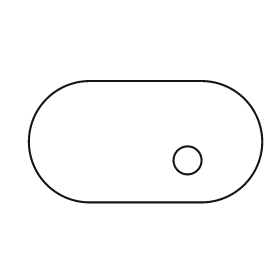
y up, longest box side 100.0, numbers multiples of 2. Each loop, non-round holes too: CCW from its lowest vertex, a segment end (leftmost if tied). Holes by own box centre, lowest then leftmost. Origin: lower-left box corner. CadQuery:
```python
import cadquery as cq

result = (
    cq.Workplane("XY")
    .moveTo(26.0, 0.0)
    .lineTo(74.0, 0.0)
    .threePointArc((100.0, 26.0), (74.0, 52.0))
    .lineTo(26.0, 52.0)
    .threePointArc((0.0, 26.0), (26.0, 0.0))
    .close()
    .moveTo(68.0, 18.0)
    .circle(6.0)
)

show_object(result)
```